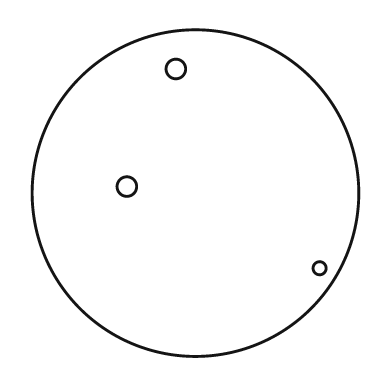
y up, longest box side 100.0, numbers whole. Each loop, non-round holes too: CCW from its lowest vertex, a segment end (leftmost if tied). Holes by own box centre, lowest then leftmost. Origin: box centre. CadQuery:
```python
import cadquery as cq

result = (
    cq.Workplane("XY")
    .moveTo(0.0, 0.0)
    .circle(50.0)
    .moveTo(38.0, -23.0)
    .circle(2.0)
    .moveTo(-21.0, 2.0)
    .circle(3.0)
    .moveTo(-6.0, 38.0)
    .circle(3.0)
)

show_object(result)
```